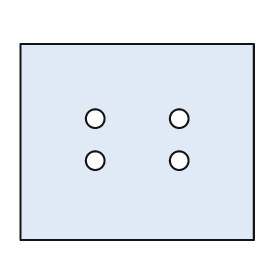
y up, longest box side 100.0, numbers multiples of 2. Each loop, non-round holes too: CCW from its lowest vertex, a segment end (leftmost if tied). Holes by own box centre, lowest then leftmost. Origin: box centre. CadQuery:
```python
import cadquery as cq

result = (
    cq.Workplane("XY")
    .moveTo(-50.0, -42.0)
    .lineTo(50.0, -42.0)
    .lineTo(50.0, 42.0)
    .lineTo(-50.0, 42.0)
    .close()
    .moveTo(-18.0, -8.0)
    .circle(4.0)
    .moveTo(18.0, -8.0)
    .circle(4.0)
    .moveTo(-18.0, 10.0)
    .circle(4.0)
    .moveTo(18.0, 10.0)
    .circle(4.0)
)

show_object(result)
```